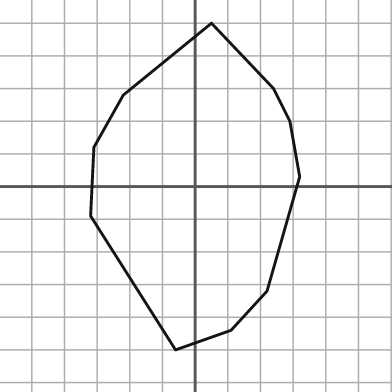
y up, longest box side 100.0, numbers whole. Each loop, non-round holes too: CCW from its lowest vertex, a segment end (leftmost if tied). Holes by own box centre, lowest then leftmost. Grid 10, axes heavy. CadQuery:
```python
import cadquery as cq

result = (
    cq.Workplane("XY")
    .moveTo(-6.0, -50.0)
    .lineTo(11.0, -44.0)
    .lineTo(22.0, -32.0)
    .lineTo(32.0, 3.0)
    .lineTo(29.0, 20.0)
    .lineTo(24.0, 30.0)
    .lineTo(5.0, 50.0)
    .lineTo(-22.0, 28.0)
    .lineTo(-31.0, 12.0)
    .lineTo(-32.0, -9.0)
    .close()
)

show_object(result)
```